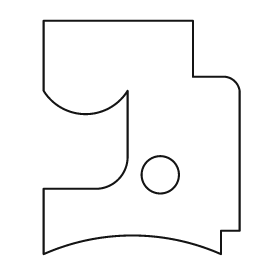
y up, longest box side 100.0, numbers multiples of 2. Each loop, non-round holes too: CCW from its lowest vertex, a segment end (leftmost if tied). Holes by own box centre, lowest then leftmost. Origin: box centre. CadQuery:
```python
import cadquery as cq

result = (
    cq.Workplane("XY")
    .moveTo(-42.0, -50.0)
    .threePointArc((-4.0, -42.0), (34.0, -50.0))
    .lineTo(34.0, -40.0)
    .lineTo(42.0, -40.0)
    .lineTo(42.0, 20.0)
    .threePointArc((40.0, 24.0), (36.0, 26.0))
    .lineTo(22.0, 26.0)
    .lineTo(22.0, 50.0)
    .lineTo(-42.0, 50.0)
    .lineTo(-42.0, 20.0)
    .threePointArc((-24.0, 10.0), (-6.0, 20.0))
    .lineTo(-6.0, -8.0)
    .threePointArc((-10.0, -18.0), (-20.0, -22.0))
    .lineTo(-42.0, -22.0)
    .close()
    .moveTo(8.0, -16.0)
    .circle(8.0)
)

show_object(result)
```